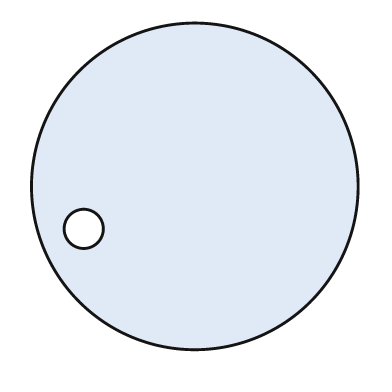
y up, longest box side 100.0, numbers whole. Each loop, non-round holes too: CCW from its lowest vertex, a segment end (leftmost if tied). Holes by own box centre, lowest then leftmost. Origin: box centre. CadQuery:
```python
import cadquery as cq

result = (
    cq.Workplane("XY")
    .moveTo(0.0, 0.0)
    .circle(50.0)
    .moveTo(-34.0, -13.0)
    .circle(6.0)
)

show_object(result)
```